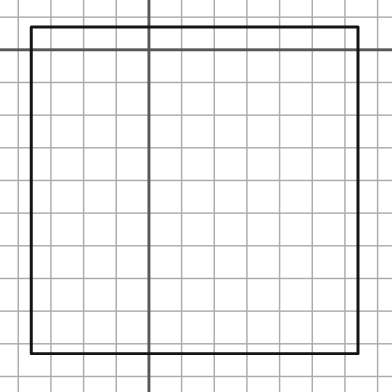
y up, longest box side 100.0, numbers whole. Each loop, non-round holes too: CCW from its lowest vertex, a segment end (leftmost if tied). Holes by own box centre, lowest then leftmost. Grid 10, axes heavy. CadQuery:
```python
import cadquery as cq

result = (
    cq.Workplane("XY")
    .moveTo(-36.0, -93.0)
    .lineTo(64.0, -93.0)
    .lineTo(64.0, 7.0)
    .lineTo(-36.0, 7.0)
    .close()
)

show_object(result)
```